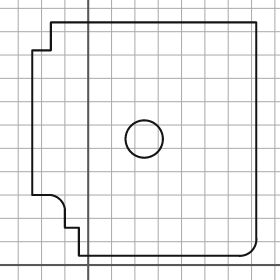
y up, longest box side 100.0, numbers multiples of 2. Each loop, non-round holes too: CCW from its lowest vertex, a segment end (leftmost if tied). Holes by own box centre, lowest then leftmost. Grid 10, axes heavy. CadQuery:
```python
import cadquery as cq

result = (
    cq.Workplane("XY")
    .moveTo(-4.0, 4.0)
    .lineTo(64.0, 4.0)
    .threePointArc((70.0, 6.0), (72.0, 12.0))
    .lineTo(72.0, 104.0)
    .lineTo(-16.0, 104.0)
    .lineTo(-16.0, 92.0)
    .lineTo(-24.0, 92.0)
    .lineTo(-24.0, 30.0)
    .lineTo(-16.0, 30.0)
    .threePointArc((-12.0, 28.0), (-10.0, 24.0))
    .lineTo(-10.0, 16.0)
    .lineTo(-4.0, 16.0)
    .close()
    .moveTo(24.0, 54.0)
    .circle(8.0)
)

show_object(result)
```